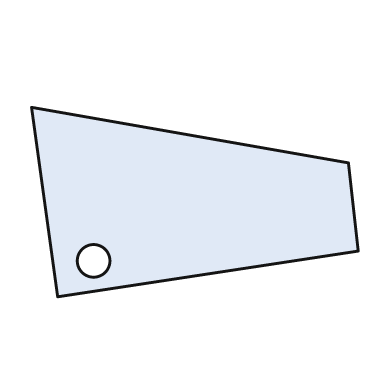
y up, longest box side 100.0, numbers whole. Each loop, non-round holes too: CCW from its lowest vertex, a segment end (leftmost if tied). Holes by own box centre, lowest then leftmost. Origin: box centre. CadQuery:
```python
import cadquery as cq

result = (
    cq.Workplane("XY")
    .moveTo(-42.0, -29.0)
    .lineTo(50.0, -15.0)
    .lineTo(47.0, 12.0)
    .lineTo(-50.0, 29.0)
    .close()
    .moveTo(-31.0, -18.0)
    .circle(5.0)
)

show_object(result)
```